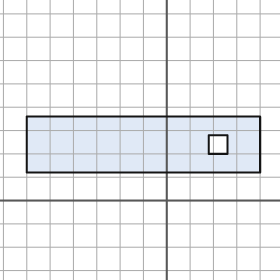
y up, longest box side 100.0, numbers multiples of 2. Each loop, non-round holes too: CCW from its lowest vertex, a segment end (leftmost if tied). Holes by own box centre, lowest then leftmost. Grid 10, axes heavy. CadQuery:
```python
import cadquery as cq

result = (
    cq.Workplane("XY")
    .moveTo(-60.0, 12.0)
    .lineTo(40.0, 12.0)
    .lineTo(40.0, 36.0)
    .lineTo(-60.0, 36.0)
    .close()
    .moveTo(18.0, 20.0)
    .lineTo(26.0, 20.0)
    .lineTo(26.0, 28.0)
    .lineTo(18.0, 28.0)
    .close()
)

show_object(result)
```